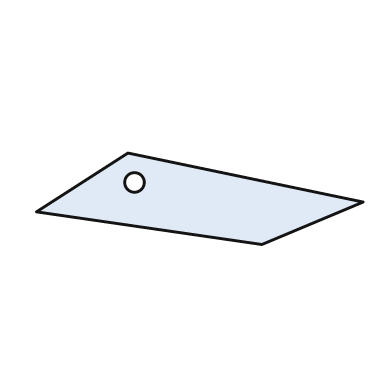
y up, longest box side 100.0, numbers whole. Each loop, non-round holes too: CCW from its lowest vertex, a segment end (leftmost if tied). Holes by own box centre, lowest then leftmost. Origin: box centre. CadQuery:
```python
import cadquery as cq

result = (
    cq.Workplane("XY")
    .moveTo(19.0, -14.0)
    .lineTo(50.0, -1.0)
    .lineTo(-22.0, 14.0)
    .lineTo(-50.0, -4.0)
    .close()
    .moveTo(-20.0, 5.0)
    .circle(3.0)
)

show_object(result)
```